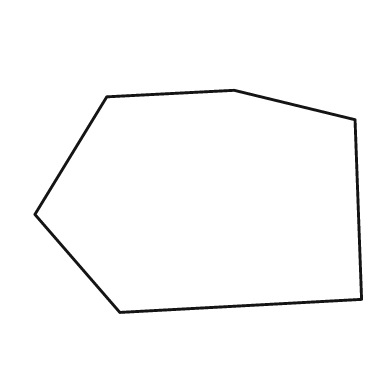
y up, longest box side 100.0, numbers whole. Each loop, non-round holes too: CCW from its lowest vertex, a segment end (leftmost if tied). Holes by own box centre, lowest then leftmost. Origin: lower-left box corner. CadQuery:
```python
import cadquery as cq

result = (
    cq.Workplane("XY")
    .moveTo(26.0, 0.0)
    .lineTo(100.0, 4.0)
    .lineTo(98.0, 59.0)
    .lineTo(61.0, 68.0)
    .lineTo(22.0, 66.0)
    .lineTo(0.0, 30.0)
    .close()
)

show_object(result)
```